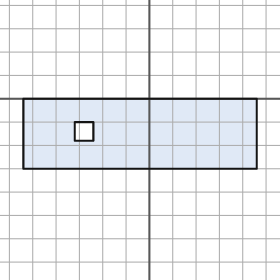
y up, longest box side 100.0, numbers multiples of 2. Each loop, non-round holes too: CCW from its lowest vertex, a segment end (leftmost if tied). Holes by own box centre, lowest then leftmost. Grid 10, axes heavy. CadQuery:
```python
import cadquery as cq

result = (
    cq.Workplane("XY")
    .moveTo(-54.0, -30.0)
    .lineTo(46.0, -30.0)
    .lineTo(46.0, 0.0)
    .lineTo(-54.0, 0.0)
    .close()
    .moveTo(-32.0, -18.0)
    .lineTo(-24.0, -18.0)
    .lineTo(-24.0, -10.0)
    .lineTo(-32.0, -10.0)
    .close()
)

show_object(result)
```